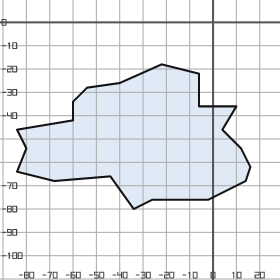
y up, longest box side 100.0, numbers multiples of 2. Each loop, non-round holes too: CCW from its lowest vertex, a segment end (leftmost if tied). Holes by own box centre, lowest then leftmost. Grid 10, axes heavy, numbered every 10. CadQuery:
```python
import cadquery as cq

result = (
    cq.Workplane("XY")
    .moveTo(-34.0, -80.0)
    .lineTo(-26.0, -76.0)
    .lineTo(-2.0, -76.0)
    .lineTo(14.0, -68.0)
    .lineTo(16.0, -62.0)
    .lineTo(12.0, -54.0)
    .lineTo(4.0, -46.0)
    .lineTo(10.0, -36.0)
    .lineTo(-6.0, -36.0)
    .lineTo(-6.0, -22.0)
    .lineTo(-22.0, -18.0)
    .lineTo(-40.0, -26.0)
    .lineTo(-54.0, -28.0)
    .lineTo(-60.0, -34.0)
    .lineTo(-60.0, -42.0)
    .lineTo(-84.0, -46.0)
    .lineTo(-80.0, -54.0)
    .lineTo(-84.0, -64.0)
    .lineTo(-68.0, -68.0)
    .lineTo(-44.0, -66.0)
    .close()
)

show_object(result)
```